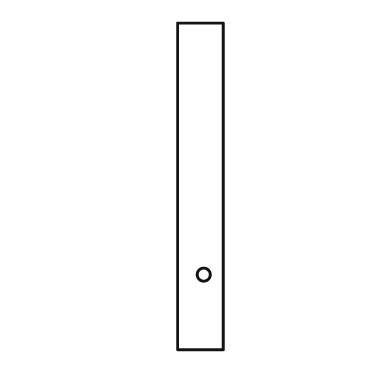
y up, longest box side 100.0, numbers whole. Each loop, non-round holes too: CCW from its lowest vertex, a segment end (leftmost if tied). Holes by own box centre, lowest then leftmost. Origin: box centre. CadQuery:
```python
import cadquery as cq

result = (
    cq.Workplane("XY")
    .moveTo(-7.0, -50.0)
    .lineTo(7.0, -50.0)
    .lineTo(7.0, 50.0)
    .lineTo(-7.0, 50.0)
    .close()
    .moveTo(1.0, -27.0)
    .circle(2.0)
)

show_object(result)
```